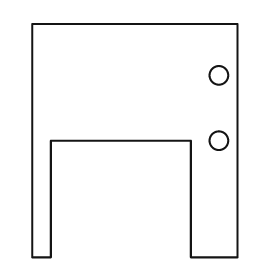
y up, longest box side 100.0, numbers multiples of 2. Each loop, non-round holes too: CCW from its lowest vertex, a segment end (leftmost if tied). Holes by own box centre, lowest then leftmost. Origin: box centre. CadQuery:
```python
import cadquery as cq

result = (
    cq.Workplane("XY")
    .moveTo(-44.0, -50.0)
    .lineTo(-36.0, -50.0)
    .lineTo(-36.0, 0.0)
    .lineTo(24.0, 0.0)
    .lineTo(24.0, -50.0)
    .lineTo(44.0, -50.0)
    .lineTo(44.0, 50.0)
    .lineTo(-44.0, 50.0)
    .close()
    .moveTo(36.0, 0.0)
    .circle(4.0)
    .moveTo(36.0, 28.0)
    .circle(4.0)
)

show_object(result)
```